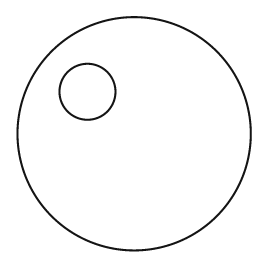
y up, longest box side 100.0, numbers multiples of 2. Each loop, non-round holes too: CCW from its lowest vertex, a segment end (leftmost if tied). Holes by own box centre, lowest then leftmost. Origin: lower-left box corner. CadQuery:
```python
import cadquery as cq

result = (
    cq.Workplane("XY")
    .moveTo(50.0, 50.0)
    .circle(50.0)
    .moveTo(30.0, 68.0)
    .circle(12.0)
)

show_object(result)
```